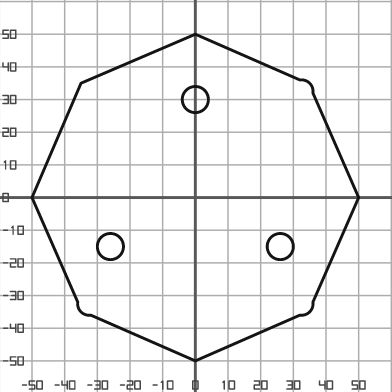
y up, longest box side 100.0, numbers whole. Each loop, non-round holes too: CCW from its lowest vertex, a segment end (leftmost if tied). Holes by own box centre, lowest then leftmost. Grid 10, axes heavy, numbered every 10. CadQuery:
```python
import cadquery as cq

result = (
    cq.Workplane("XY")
    .moveTo(0.0, -50.0)
    .lineTo(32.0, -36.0)
    .threePointArc((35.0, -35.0), (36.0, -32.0))
    .lineTo(50.0, 0.0)
    .lineTo(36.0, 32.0)
    .threePointArc((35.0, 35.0), (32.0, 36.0))
    .lineTo(0.0, 50.0)
    .lineTo(-35.0, 35.0)
    .lineTo(-50.0, 0.0)
    .lineTo(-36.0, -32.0)
    .threePointArc((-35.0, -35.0), (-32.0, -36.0))
    .close()
    .moveTo(-26.0, -15.0)
    .circle(4.0)
    .moveTo(26.0, -15.0)
    .circle(4.0)
    .moveTo(0.0, 30.0)
    .circle(4.0)
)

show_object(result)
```